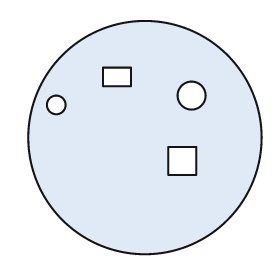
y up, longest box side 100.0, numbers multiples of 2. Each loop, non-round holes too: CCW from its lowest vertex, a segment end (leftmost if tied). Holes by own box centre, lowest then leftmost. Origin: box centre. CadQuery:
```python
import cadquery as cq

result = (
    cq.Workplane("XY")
    .moveTo(0.0, 0.0)
    .circle(50.0)
    .moveTo(10.0, -16.0)
    .lineTo(22.0, -16.0)
    .lineTo(22.0, -4.0)
    .lineTo(10.0, -4.0)
    .close()
    .moveTo(-38.0, 14.0)
    .circle(4.0)
    .moveTo(20.0, 18.0)
    .circle(6.0)
    .moveTo(-18.0, 22.0)
    .lineTo(-6.0, 22.0)
    .lineTo(-6.0, 30.0)
    .lineTo(-18.0, 30.0)
    .close()
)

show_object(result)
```